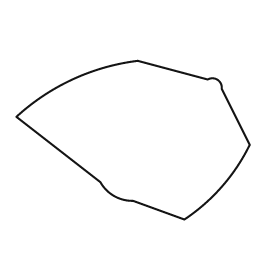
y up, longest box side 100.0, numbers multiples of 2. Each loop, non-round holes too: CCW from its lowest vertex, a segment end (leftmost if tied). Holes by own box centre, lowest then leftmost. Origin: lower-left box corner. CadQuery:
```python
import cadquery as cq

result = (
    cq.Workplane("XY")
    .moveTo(72.0, 0.0)
    .threePointArc((88.0, 14.0), (100.0, 32.0))
    .lineTo(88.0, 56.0)
    .threePointArc((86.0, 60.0), (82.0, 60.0))
    .lineTo(52.0, 68.0)
    .threePointArc((24.0, 60.0), (0.0, 44.0))
    .lineTo(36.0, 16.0)
    .threePointArc((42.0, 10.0), (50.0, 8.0))
    .close()
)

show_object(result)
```